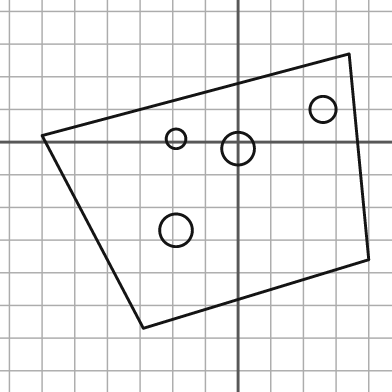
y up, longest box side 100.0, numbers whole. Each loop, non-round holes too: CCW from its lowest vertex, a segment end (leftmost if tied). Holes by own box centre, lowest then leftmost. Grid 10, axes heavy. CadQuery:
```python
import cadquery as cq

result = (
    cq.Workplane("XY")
    .moveTo(-29.0, -57.0)
    .lineTo(40.0, -36.0)
    .lineTo(34.0, 27.0)
    .lineTo(-60.0, 2.0)
    .close()
    .moveTo(-19.0, -27.0)
    .circle(5.0)
    .moveTo(0.0, -2.0)
    .circle(5.0)
    .moveTo(-19.0, 1.0)
    .circle(3.0)
    .moveTo(26.0, 10.0)
    .circle(4.0)
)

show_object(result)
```